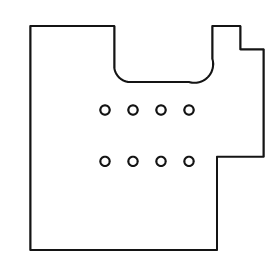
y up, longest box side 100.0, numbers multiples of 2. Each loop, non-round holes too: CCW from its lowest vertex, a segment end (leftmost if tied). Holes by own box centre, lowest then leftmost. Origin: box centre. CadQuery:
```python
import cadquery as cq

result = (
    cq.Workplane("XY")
    .moveTo(-50.0, -48.0)
    .lineTo(30.0, -48.0)
    .lineTo(30.0, -8.0)
    .lineTo(50.0, -8.0)
    .lineTo(50.0, 38.0)
    .lineTo(40.0, 38.0)
    .lineTo(40.0, 48.0)
    .lineTo(28.0, 48.0)
    .lineTo(28.0, 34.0)
    .threePointArc((26.0, 26.0), (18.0, 24.0))
    .lineTo(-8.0, 24.0)
    .threePointArc((-12.0, 26.0), (-14.0, 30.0))
    .lineTo(-14.0, 48.0)
    .lineTo(-50.0, 48.0)
    .close()
    .moveTo(-18.0, -10.0)
    .circle(2.0)
    .moveTo(-6.0, -10.0)
    .circle(2.0)
    .moveTo(6.0, -10.0)
    .circle(2.0)
    .moveTo(18.0, -10.0)
    .circle(2.0)
    .moveTo(-18.0, 12.0)
    .circle(2.0)
    .moveTo(-6.0, 12.0)
    .circle(2.0)
    .moveTo(6.0, 12.0)
    .circle(2.0)
    .moveTo(18.0, 12.0)
    .circle(2.0)
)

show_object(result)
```